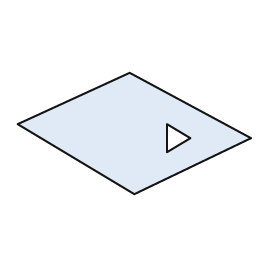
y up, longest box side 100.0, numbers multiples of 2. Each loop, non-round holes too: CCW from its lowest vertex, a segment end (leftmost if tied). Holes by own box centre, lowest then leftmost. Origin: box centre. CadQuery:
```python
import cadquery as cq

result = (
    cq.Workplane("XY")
    .moveTo(0.0, -26.0)
    .lineTo(50.0, -2.0)
    .lineTo(-2.0, 26.0)
    .lineTo(-50.0, 4.0)
    .close()
    .moveTo(14.0, -8.0)
    .lineTo(24.0, -2.0)
    .lineTo(14.0, 4.0)
    .close()
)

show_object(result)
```